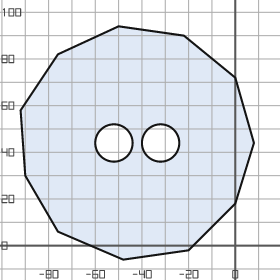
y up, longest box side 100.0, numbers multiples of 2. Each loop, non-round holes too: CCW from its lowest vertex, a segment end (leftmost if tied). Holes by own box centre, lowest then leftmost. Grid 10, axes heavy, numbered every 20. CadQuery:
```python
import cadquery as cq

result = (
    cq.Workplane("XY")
    .moveTo(-48.0, -6.0)
    .lineTo(-20.0, -2.0)
    .lineTo(0.0, 18.0)
    .lineTo(8.0, 44.0)
    .lineTo(0.0, 72.0)
    .lineTo(-22.0, 90.0)
    .lineTo(-50.0, 94.0)
    .lineTo(-76.0, 82.0)
    .lineTo(-92.0, 58.0)
    .lineTo(-90.0, 30.0)
    .lineTo(-76.0, 6.0)
    .close()
    .moveTo(-52.0, 44.0)
    .circle(8.0)
    .moveTo(-32.0, 44.0)
    .circle(8.0)
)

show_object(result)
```